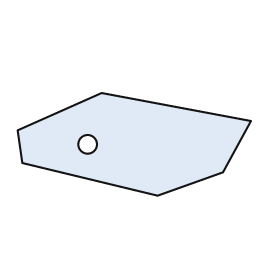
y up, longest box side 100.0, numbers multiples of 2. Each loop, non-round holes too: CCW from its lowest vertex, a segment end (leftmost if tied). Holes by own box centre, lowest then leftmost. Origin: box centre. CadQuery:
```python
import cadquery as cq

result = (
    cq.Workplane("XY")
    .moveTo(10.0, -22.0)
    .lineTo(38.0, -12.0)
    .lineTo(50.0, 10.0)
    .lineTo(-14.0, 22.0)
    .lineTo(-50.0, 6.0)
    .lineTo(-48.0, -8.0)
    .close()
    .moveTo(-20.0, 0.0)
    .circle(4.0)
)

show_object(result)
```